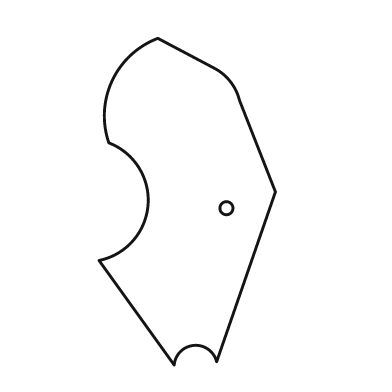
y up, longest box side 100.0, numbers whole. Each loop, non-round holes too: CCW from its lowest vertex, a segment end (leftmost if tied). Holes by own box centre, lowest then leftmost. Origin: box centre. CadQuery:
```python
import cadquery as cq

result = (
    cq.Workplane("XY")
    .moveTo(-4.0, -50.0)
    .threePointArc((2.0, -44.0), (9.0, -49.0))
    .lineTo(27.0, 3.0)
    .lineTo(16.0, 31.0)
    .threePointArc((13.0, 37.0), (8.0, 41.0))
    .lineTo(-9.0, 50.0)
    .threePointArc((-23.0, 37.0), (-24.0, 18.0))
    .threePointArc((-12.0, -1.0), (-27.0, -18.0))
    .close()
    .moveTo(12.0, -2.0)
    .circle(2.0)
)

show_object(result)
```